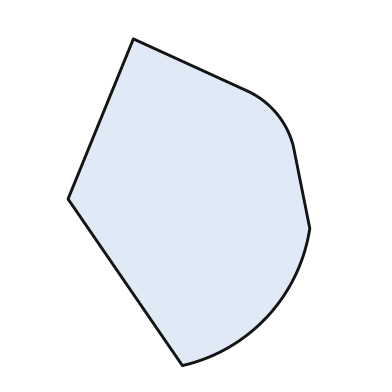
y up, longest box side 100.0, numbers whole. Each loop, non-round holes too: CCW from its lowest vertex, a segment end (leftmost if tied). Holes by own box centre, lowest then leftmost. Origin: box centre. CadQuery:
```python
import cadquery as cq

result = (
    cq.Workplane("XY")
    .moveTo(-2.0, -50.0)
    .threePointArc((24.0, -35.0), (37.0, -8.0))
    .lineTo(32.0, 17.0)
    .threePointArc((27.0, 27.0), (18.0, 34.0))
    .lineTo(-17.0, 50.0)
    .lineTo(-37.0, 1.0)
    .close()
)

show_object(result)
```